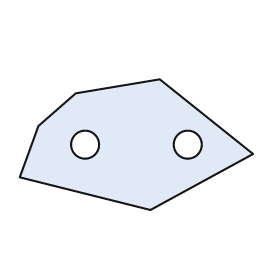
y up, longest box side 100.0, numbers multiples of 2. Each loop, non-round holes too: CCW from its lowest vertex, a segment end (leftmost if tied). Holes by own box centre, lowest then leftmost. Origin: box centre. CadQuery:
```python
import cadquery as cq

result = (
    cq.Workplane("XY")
    .moveTo(6.0, -28.0)
    .lineTo(50.0, -4.0)
    .lineTo(10.0, 28.0)
    .lineTo(-26.0, 22.0)
    .lineTo(-42.0, 8.0)
    .lineTo(-50.0, -14.0)
    .close()
    .moveTo(-22.0, 0.0)
    .circle(6.0)
    .moveTo(22.0, 0.0)
    .circle(6.0)
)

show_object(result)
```